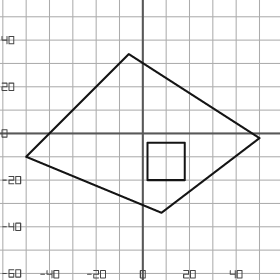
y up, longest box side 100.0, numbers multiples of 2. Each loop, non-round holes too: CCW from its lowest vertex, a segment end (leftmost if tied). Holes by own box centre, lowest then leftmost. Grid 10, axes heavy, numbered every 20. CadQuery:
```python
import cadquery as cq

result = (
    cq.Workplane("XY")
    .moveTo(8.0, -34.0)
    .lineTo(50.0, -2.0)
    .lineTo(-6.0, 34.0)
    .lineTo(-50.0, -10.0)
    .close()
    .moveTo(2.0, -20.0)
    .lineTo(18.0, -20.0)
    .lineTo(18.0, -4.0)
    .lineTo(2.0, -4.0)
    .close()
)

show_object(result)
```